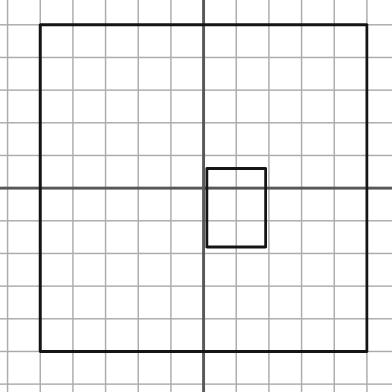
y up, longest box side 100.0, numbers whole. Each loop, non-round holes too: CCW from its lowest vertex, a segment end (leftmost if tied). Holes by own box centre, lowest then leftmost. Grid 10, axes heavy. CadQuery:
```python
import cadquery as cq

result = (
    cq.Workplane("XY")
    .moveTo(-50.0, -50.0)
    .lineTo(50.0, -50.0)
    .lineTo(50.0, 50.0)
    .lineTo(-50.0, 50.0)
    .close()
    .moveTo(1.0, -18.0)
    .lineTo(19.0, -18.0)
    .lineTo(19.0, 6.0)
    .lineTo(1.0, 6.0)
    .close()
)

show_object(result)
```